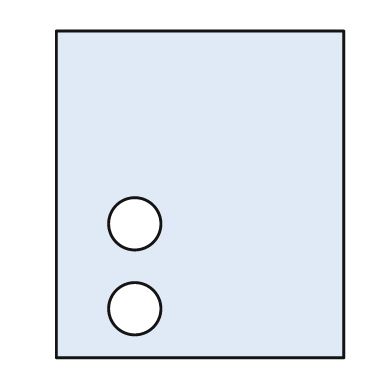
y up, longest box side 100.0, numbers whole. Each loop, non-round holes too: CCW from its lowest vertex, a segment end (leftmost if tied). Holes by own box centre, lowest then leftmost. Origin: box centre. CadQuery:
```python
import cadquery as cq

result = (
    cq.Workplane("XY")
    .moveTo(-44.0, -50.0)
    .lineTo(44.0, -50.0)
    .lineTo(44.0, 50.0)
    .lineTo(-44.0, 50.0)
    .close()
    .moveTo(-20.0, -35.0)
    .circle(8.0)
    .moveTo(-20.0, -9.0)
    .circle(8.0)
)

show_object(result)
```